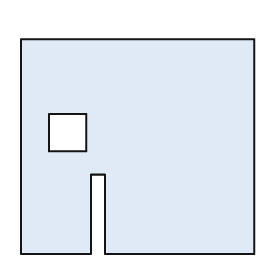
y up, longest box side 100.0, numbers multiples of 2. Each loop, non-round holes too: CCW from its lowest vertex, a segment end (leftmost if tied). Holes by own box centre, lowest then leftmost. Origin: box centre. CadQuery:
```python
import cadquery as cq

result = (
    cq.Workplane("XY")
    .moveTo(-50.0, -46.0)
    .lineTo(-20.0, -46.0)
    .lineTo(-20.0, -12.0)
    .lineTo(-14.0, -12.0)
    .lineTo(-14.0, -46.0)
    .lineTo(50.0, -46.0)
    .lineTo(50.0, 46.0)
    .lineTo(-50.0, 46.0)
    .close()
    .moveTo(-38.0, -2.0)
    .lineTo(-22.0, -2.0)
    .lineTo(-22.0, 14.0)
    .lineTo(-38.0, 14.0)
    .close()
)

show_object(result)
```